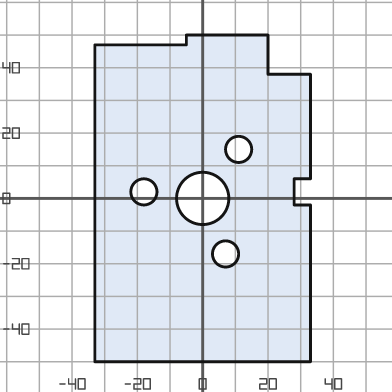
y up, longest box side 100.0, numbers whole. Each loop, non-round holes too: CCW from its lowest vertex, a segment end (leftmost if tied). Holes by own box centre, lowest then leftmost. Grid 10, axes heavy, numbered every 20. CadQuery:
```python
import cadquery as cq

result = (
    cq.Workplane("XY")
    .moveTo(-33.0, -50.0)
    .lineTo(33.0, -50.0)
    .lineTo(33.0, -2.0)
    .lineTo(28.0, -2.0)
    .lineTo(28.0, 6.0)
    .lineTo(33.0, 6.0)
    .lineTo(33.0, 38.0)
    .lineTo(20.0, 38.0)
    .lineTo(20.0, 50.0)
    .lineTo(-5.0, 50.0)
    .lineTo(-5.0, 47.0)
    .lineTo(-33.0, 47.0)
    .close()
    .moveTo(7.0, -17.0)
    .circle(4.0)
    .moveTo(0.0, 0.0)
    .circle(8.0)
    .moveTo(-18.0, 2.0)
    .circle(4.0)
    .moveTo(11.0, 15.0)
    .circle(4.0)
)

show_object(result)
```